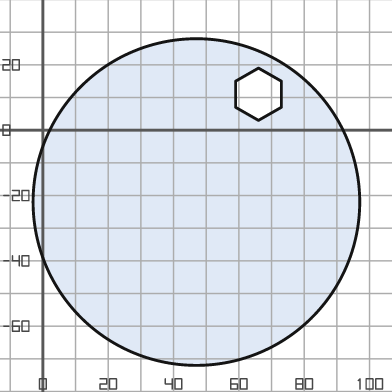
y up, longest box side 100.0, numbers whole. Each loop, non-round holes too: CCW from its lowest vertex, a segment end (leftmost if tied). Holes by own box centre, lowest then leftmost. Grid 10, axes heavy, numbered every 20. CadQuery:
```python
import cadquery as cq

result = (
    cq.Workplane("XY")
    .moveTo(47.0, -22.0)
    .circle(50.0)
    .moveTo(66.0, 3.0)
    .lineTo(73.0, 7.0)
    .lineTo(73.0, 15.0)
    .lineTo(66.0, 19.0)
    .lineTo(59.0, 15.0)
    .lineTo(59.0, 7.0)
    .close()
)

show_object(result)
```